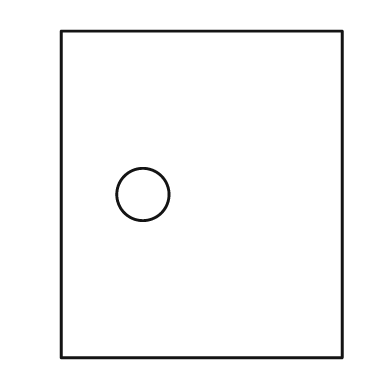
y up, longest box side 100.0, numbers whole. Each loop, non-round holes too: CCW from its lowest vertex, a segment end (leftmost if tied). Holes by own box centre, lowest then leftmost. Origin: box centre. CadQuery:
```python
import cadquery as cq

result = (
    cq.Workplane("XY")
    .moveTo(-43.0, -50.0)
    .lineTo(43.0, -50.0)
    .lineTo(43.0, 50.0)
    .lineTo(-43.0, 50.0)
    .close()
    .moveTo(-18.0, 0.0)
    .circle(8.0)
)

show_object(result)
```